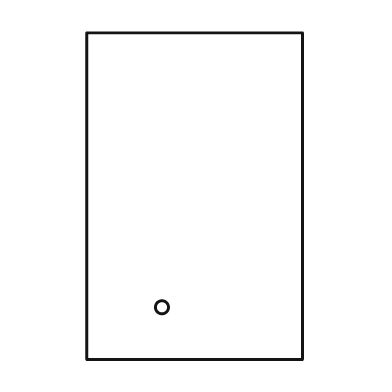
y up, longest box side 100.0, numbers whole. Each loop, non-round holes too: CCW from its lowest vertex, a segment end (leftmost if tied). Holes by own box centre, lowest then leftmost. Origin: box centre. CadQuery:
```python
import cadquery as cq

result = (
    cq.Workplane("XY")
    .moveTo(-33.0, -50.0)
    .lineTo(33.0, -50.0)
    .lineTo(33.0, 50.0)
    .lineTo(-33.0, 50.0)
    .close()
    .moveTo(-10.0, -34.0)
    .circle(2.0)
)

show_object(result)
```